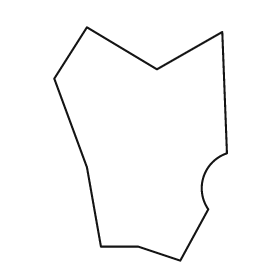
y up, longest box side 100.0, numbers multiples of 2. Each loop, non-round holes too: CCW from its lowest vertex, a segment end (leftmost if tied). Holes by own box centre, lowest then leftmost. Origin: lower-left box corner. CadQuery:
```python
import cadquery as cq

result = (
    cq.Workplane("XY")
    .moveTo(54.0, 0.0)
    .lineTo(66.0, 22.0)
    .threePointArc((64.0, 36.0), (74.0, 46.0))
    .lineTo(72.0, 98.0)
    .lineTo(44.0, 82.0)
    .lineTo(14.0, 100.0)
    .lineTo(0.0, 78.0)
    .lineTo(14.0, 40.0)
    .lineTo(20.0, 6.0)
    .lineTo(36.0, 6.0)
    .close()
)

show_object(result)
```